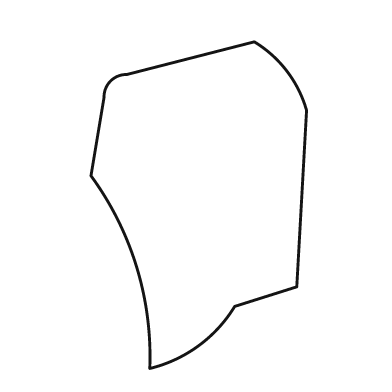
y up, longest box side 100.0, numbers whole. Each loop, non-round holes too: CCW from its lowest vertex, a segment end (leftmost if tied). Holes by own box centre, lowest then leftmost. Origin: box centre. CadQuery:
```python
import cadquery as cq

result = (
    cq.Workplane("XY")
    .moveTo(-15.0, -50.0)
    .threePointArc((0.0, -43.0), (11.0, -31.0))
    .lineTo(30.0, -25.0)
    .lineTo(33.0, 29.0)
    .threePointArc((27.0, 41.0), (17.0, 50.0))
    .lineTo(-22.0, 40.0)
    .threePointArc((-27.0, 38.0), (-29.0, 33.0))
    .lineTo(-33.0, 9.0)
    .threePointArc((-19.0, -19.0), (-15.0, -50.0))
    .close()
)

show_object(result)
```